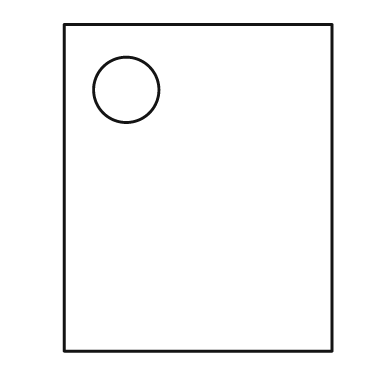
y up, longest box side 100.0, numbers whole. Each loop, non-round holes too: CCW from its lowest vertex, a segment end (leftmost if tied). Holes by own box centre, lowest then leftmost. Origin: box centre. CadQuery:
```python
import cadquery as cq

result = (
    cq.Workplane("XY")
    .moveTo(-41.0, -50.0)
    .lineTo(41.0, -50.0)
    .lineTo(41.0, 50.0)
    .lineTo(-41.0, 50.0)
    .close()
    .moveTo(-22.0, 30.0)
    .circle(10.0)
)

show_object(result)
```